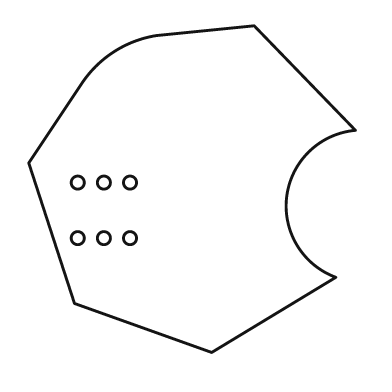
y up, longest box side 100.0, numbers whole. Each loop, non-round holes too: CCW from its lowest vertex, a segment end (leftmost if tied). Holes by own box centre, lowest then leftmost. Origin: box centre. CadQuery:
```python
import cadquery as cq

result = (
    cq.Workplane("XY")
    .moveTo(6.0, -50.0)
    .lineTo(44.0, -27.0)
    .threePointArc((29.0, -2.0), (50.0, 18.0))
    .lineTo(19.0, 50.0)
    .lineTo(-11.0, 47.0)
    .threePointArc((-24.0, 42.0), (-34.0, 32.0))
    .lineTo(-50.0, 8.0)
    .lineTo(-36.0, -35.0)
    .close()
    .moveTo(-35.0, -15.0)
    .circle(2.0)
    .moveTo(-27.0, -15.0)
    .circle(2.0)
    .moveTo(-19.0, -15.0)
    .circle(2.0)
    .moveTo(-35.0, 2.0)
    .circle(2.0)
    .moveTo(-27.0, 2.0)
    .circle(2.0)
    .moveTo(-19.0, 2.0)
    .circle(2.0)
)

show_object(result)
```